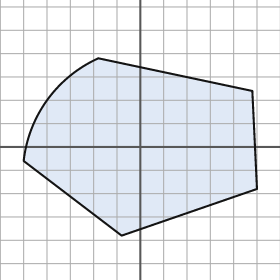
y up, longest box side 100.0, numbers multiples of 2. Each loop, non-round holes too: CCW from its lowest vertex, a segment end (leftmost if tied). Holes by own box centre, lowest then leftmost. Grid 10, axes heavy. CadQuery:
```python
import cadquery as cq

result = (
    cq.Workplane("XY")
    .moveTo(-8.0, -38.0)
    .lineTo(50.0, -18.0)
    .lineTo(48.0, 24.0)
    .lineTo(-18.0, 38.0)
    .threePointArc((-40.0, 20.0), (-50.0, -6.0))
    .close()
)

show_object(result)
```